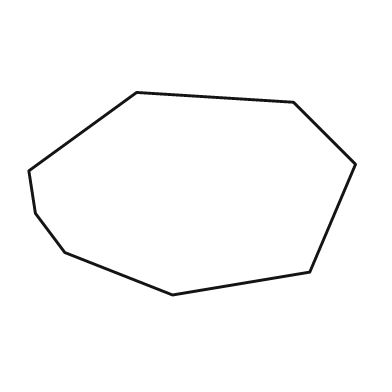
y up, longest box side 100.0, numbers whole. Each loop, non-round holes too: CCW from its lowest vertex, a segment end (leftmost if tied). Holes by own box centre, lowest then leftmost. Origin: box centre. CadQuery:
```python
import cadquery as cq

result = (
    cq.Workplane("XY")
    .moveTo(-6.0, -31.0)
    .lineTo(36.0, -24.0)
    .lineTo(50.0, 9.0)
    .lineTo(31.0, 28.0)
    .lineTo(-17.0, 31.0)
    .lineTo(-50.0, 7.0)
    .lineTo(-48.0, -6.0)
    .lineTo(-39.0, -18.0)
    .close()
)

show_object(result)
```